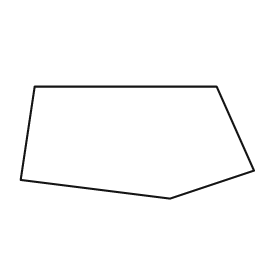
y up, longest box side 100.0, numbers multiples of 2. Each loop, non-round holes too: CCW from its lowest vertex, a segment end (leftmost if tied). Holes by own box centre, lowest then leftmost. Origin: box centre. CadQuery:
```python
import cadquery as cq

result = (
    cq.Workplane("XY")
    .moveTo(14.0, -24.0)
    .lineTo(50.0, -12.0)
    .lineTo(34.0, 24.0)
    .lineTo(-44.0, 24.0)
    .lineTo(-50.0, -16.0)
    .close()
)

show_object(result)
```